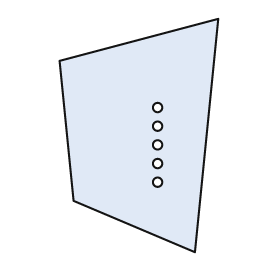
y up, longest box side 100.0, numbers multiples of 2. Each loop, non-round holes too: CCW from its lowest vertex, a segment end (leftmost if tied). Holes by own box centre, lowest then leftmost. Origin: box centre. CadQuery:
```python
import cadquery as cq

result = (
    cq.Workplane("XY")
    .moveTo(24.0, -50.0)
    .lineTo(34.0, 50.0)
    .lineTo(-34.0, 32.0)
    .lineTo(-28.0, -28.0)
    .close()
    .moveTo(8.0, -20.0)
    .circle(2.0)
    .moveTo(8.0, -12.0)
    .circle(2.0)
    .moveTo(8.0, -4.0)
    .circle(2.0)
    .moveTo(8.0, 4.0)
    .circle(2.0)
    .moveTo(8.0, 12.0)
    .circle(2.0)
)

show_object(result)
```